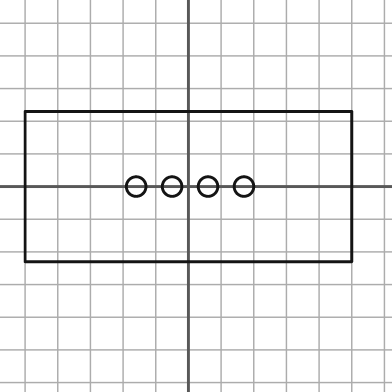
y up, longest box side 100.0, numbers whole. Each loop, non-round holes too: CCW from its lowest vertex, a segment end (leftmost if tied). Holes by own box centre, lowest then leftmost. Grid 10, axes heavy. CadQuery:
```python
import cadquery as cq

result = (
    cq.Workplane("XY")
    .moveTo(-50.0, -23.0)
    .lineTo(50.0, -23.0)
    .lineTo(50.0, 23.0)
    .lineTo(-50.0, 23.0)
    .close()
    .moveTo(-16.0, 0.0)
    .circle(3.0)
    .moveTo(-5.0, 0.0)
    .circle(3.0)
    .moveTo(6.0, 0.0)
    .circle(3.0)
    .moveTo(17.0, 0.0)
    .circle(3.0)
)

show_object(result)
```